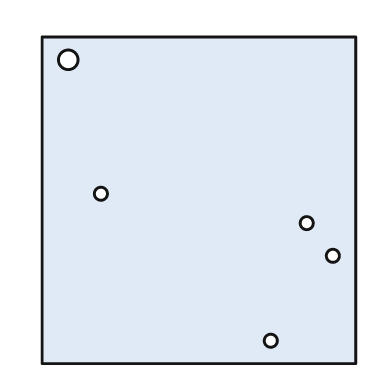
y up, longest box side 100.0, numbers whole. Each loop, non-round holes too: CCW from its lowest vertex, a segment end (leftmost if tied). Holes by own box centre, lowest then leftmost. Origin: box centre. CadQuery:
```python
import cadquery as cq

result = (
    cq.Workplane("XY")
    .moveTo(-48.0, -50.0)
    .lineTo(48.0, -50.0)
    .lineTo(48.0, 50.0)
    .lineTo(-48.0, 50.0)
    .close()
    .moveTo(22.0, -43.0)
    .circle(2.0)
    .moveTo(41.0, -17.0)
    .circle(2.0)
    .moveTo(33.0, -7.0)
    .circle(2.0)
    .moveTo(-30.0, 2.0)
    .circle(2.0)
    .moveTo(-40.0, 43.0)
    .circle(3.0)
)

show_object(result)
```